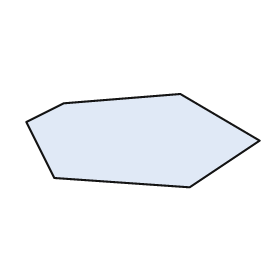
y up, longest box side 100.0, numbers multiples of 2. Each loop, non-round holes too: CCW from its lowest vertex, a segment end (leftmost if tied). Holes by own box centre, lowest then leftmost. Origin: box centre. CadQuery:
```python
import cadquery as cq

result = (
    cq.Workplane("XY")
    .moveTo(20.0, -20.0)
    .lineTo(50.0, 0.0)
    .lineTo(16.0, 20.0)
    .lineTo(-34.0, 16.0)
    .lineTo(-50.0, 8.0)
    .lineTo(-38.0, -16.0)
    .close()
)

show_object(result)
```